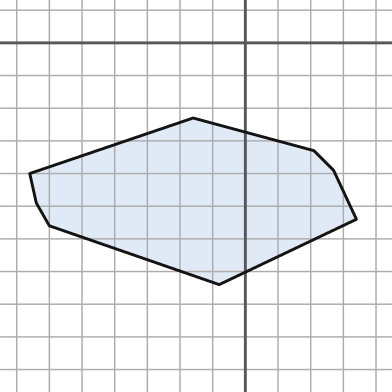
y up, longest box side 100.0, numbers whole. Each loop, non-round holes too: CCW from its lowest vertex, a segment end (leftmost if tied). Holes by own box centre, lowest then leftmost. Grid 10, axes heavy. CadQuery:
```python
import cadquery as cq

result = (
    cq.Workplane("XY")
    .moveTo(-8.0, -74.0)
    .lineTo(34.0, -54.0)
    .lineTo(27.0, -39.0)
    .lineTo(21.0, -33.0)
    .lineTo(-16.0, -23.0)
    .lineTo(-66.0, -40.0)
    .lineTo(-64.0, -49.0)
    .lineTo(-60.0, -56.0)
    .close()
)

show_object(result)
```